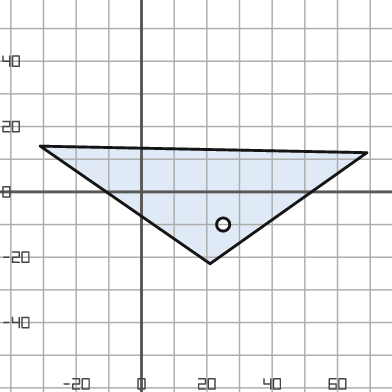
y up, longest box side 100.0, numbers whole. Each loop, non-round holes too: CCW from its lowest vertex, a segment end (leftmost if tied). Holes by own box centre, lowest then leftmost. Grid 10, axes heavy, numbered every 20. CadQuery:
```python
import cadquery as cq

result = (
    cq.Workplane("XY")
    .moveTo(21.0, -22.0)
    .lineTo(69.0, 12.0)
    .lineTo(-31.0, 14.0)
    .close()
    .moveTo(25.0, -10.0)
    .circle(2.0)
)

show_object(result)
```